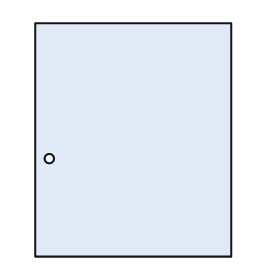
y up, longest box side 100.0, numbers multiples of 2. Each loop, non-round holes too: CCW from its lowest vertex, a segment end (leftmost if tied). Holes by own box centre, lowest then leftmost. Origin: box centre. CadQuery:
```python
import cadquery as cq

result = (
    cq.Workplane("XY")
    .moveTo(-42.0, -50.0)
    .lineTo(42.0, -50.0)
    .lineTo(42.0, 50.0)
    .lineTo(-42.0, 50.0)
    .close()
    .moveTo(-36.0, -8.0)
    .circle(2.0)
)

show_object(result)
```